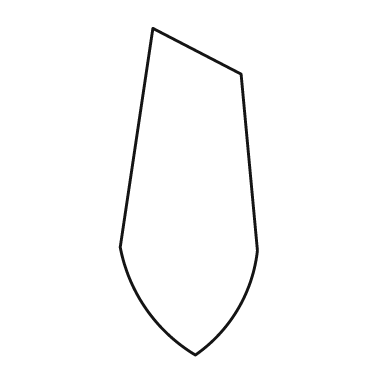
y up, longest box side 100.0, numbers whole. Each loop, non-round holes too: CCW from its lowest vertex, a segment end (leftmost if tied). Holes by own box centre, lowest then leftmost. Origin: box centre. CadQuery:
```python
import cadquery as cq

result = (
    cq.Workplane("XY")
    .moveTo(2.0, -50.0)
    .threePointArc((15.0, -36.0), (21.0, -18.0))
    .lineTo(16.0, 36.0)
    .lineTo(-11.0, 50.0)
    .lineTo(-21.0, -17.0)
    .threePointArc((-13.0, -36.0), (2.0, -50.0))
    .close()
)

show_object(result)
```